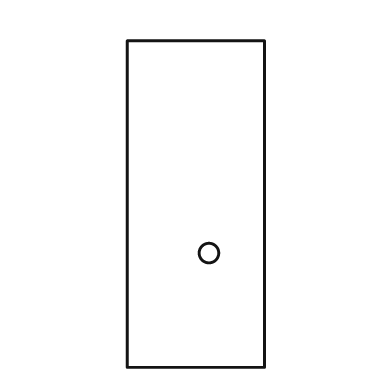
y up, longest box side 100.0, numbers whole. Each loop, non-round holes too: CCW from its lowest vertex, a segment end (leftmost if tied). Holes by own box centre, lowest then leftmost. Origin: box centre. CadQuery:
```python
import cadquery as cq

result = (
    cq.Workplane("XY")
    .moveTo(-21.0, -50.0)
    .lineTo(21.0, -50.0)
    .lineTo(21.0, 50.0)
    .lineTo(-21.0, 50.0)
    .close()
    .moveTo(4.0, -15.0)
    .circle(3.0)
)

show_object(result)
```